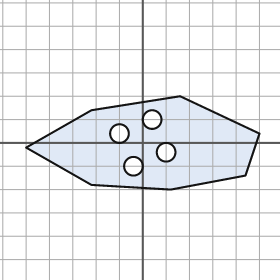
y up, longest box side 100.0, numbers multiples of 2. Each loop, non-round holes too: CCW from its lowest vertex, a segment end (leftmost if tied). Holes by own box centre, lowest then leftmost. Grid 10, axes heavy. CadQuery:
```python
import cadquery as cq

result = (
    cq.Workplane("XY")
    .moveTo(12.0, -20.0)
    .lineTo(44.0, -14.0)
    .lineTo(50.0, 4.0)
    .lineTo(16.0, 20.0)
    .lineTo(-22.0, 14.0)
    .lineTo(-50.0, -2.0)
    .lineTo(-22.0, -18.0)
    .close()
    .moveTo(-4.0, -10.0)
    .circle(4.0)
    .moveTo(10.0, -4.0)
    .circle(4.0)
    .moveTo(-10.0, 4.0)
    .circle(4.0)
    .moveTo(4.0, 10.0)
    .circle(4.0)
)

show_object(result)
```